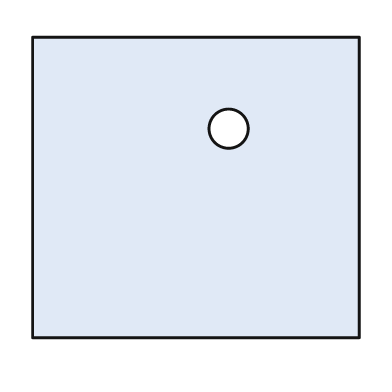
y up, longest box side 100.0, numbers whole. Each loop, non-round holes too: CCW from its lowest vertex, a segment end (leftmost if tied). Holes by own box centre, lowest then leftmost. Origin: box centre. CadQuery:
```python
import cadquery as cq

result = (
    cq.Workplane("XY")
    .moveTo(-50.0, -46.0)
    .lineTo(50.0, -46.0)
    .lineTo(50.0, 46.0)
    .lineTo(-50.0, 46.0)
    .close()
    .moveTo(10.0, 18.0)
    .circle(6.0)
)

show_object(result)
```